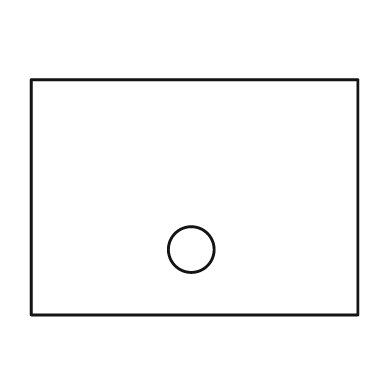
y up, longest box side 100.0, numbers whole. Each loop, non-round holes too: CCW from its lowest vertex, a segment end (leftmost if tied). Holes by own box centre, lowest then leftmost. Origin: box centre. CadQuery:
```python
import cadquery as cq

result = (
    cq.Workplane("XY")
    .moveTo(-50.0, -36.0)
    .lineTo(50.0, -36.0)
    .lineTo(50.0, 36.0)
    .lineTo(-50.0, 36.0)
    .close()
    .moveTo(-1.0, -16.0)
    .circle(7.0)
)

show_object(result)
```